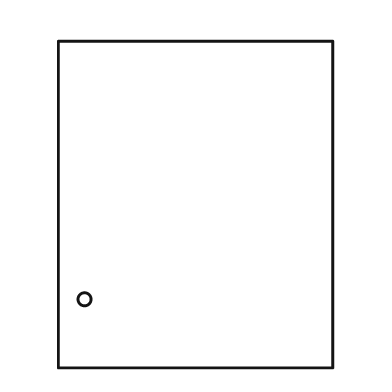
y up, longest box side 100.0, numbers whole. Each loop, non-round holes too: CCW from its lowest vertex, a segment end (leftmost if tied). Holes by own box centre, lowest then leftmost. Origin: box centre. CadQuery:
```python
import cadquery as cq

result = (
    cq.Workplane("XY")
    .moveTo(-42.0, -50.0)
    .lineTo(42.0, -50.0)
    .lineTo(42.0, 50.0)
    .lineTo(-42.0, 50.0)
    .close()
    .moveTo(-34.0, -29.0)
    .circle(2.0)
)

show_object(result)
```